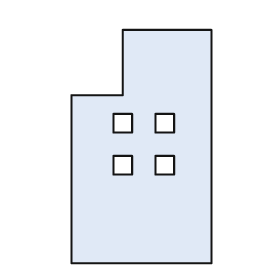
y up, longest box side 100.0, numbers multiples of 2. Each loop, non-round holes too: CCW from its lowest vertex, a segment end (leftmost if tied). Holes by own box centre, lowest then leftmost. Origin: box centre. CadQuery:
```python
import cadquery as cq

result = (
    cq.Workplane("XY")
    .moveTo(-30.0, -50.0)
    .lineTo(30.0, -50.0)
    .lineTo(30.0, 50.0)
    .lineTo(-8.0, 50.0)
    .lineTo(-8.0, 22.0)
    .lineTo(-30.0, 22.0)
    .close()
    .moveTo(-12.0, -12.0)
    .lineTo(-4.0, -12.0)
    .lineTo(-4.0, -4.0)
    .lineTo(-12.0, -4.0)
    .close()
    .moveTo(6.0, -12.0)
    .lineTo(14.0, -12.0)
    .lineTo(14.0, -4.0)
    .lineTo(6.0, -4.0)
    .close()
    .moveTo(-12.0, 6.0)
    .lineTo(-4.0, 6.0)
    .lineTo(-4.0, 14.0)
    .lineTo(-12.0, 14.0)
    .close()
    .moveTo(6.0, 6.0)
    .lineTo(14.0, 6.0)
    .lineTo(14.0, 14.0)
    .lineTo(6.0, 14.0)
    .close()
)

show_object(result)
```